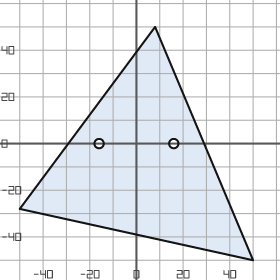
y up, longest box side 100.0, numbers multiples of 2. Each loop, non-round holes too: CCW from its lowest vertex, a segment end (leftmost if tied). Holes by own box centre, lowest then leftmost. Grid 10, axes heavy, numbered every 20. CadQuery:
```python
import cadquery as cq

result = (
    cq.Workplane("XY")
    .moveTo(50.0, -50.0)
    .lineTo(8.0, 50.0)
    .lineTo(-50.0, -28.0)
    .close()
    .moveTo(-16.0, 0.0)
    .circle(2.0)
    .moveTo(16.0, 0.0)
    .circle(2.0)
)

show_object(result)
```